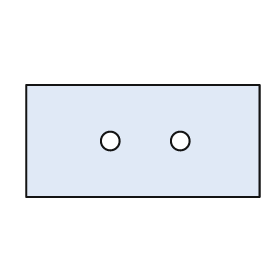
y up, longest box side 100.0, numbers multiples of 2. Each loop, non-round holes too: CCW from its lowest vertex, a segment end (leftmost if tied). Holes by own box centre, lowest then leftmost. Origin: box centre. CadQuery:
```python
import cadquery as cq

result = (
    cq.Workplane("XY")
    .moveTo(-50.0, -24.0)
    .lineTo(50.0, -24.0)
    .lineTo(50.0, 24.0)
    .lineTo(-50.0, 24.0)
    .close()
    .moveTo(-14.0, 0.0)
    .circle(4.0)
    .moveTo(16.0, 0.0)
    .circle(4.0)
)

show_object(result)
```